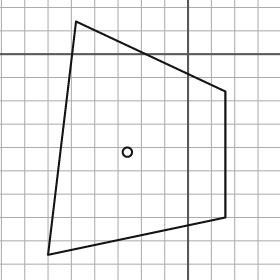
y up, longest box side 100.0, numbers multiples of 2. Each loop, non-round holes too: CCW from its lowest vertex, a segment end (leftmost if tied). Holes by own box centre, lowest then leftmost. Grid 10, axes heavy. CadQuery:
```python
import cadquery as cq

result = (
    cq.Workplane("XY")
    .moveTo(-60.0, -86.0)
    .lineTo(16.0, -70.0)
    .lineTo(16.0, -16.0)
    .lineTo(-48.0, 14.0)
    .close()
    .moveTo(-26.0, -42.0)
    .circle(2.0)
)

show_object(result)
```